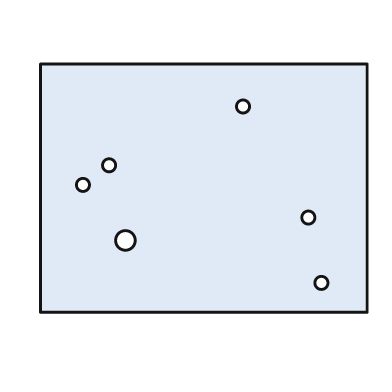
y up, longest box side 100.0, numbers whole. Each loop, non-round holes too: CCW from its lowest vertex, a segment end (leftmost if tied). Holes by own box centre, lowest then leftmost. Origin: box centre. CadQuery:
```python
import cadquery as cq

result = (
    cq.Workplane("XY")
    .moveTo(-50.0, -38.0)
    .lineTo(50.0, -38.0)
    .lineTo(50.0, 38.0)
    .lineTo(-50.0, 38.0)
    .close()
    .moveTo(36.0, -29.0)
    .circle(2.0)
    .moveTo(-24.0, -16.0)
    .circle(3.0)
    .moveTo(32.0, -9.0)
    .circle(2.0)
    .moveTo(-37.0, 1.0)
    .circle(2.0)
    .moveTo(-29.0, 7.0)
    .circle(2.0)
    .moveTo(12.0, 25.0)
    .circle(2.0)
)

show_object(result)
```